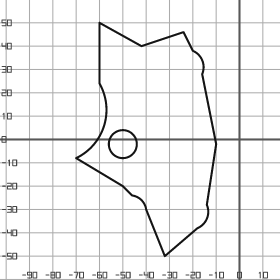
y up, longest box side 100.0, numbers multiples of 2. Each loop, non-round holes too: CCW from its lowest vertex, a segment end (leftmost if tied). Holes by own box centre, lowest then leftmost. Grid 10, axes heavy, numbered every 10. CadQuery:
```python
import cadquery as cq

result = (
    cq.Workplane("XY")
    .moveTo(-32.0, -50.0)
    .lineTo(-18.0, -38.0)
    .threePointArc((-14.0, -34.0), (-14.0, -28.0))
    .lineTo(-10.0, -2.0)
    .lineTo(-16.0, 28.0)
    .threePointArc((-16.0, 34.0), (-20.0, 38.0))
    .lineTo(-24.0, 46.0)
    .lineTo(-42.0, 40.0)
    .lineTo(-60.0, 50.0)
    .lineTo(-60.0, 24.0)
    .threePointArc((-58.0, 6.0), (-70.0, -8.0))
    .lineTo(-50.0, -20.0)
    .lineTo(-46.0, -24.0)
    .threePointArc((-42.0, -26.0), (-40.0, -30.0))
    .close()
    .moveTo(-50.0, -2.0)
    .circle(6.0)
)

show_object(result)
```